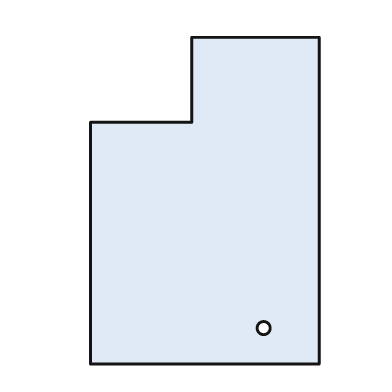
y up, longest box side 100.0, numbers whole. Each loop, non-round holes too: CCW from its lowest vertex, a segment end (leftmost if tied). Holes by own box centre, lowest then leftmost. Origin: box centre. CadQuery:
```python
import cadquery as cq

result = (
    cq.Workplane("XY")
    .moveTo(-35.0, -50.0)
    .lineTo(35.0, -50.0)
    .lineTo(35.0, 50.0)
    .lineTo(-4.0, 50.0)
    .lineTo(-4.0, 24.0)
    .lineTo(-35.0, 24.0)
    .close()
    .moveTo(18.0, -39.0)
    .circle(2.0)
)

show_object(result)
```